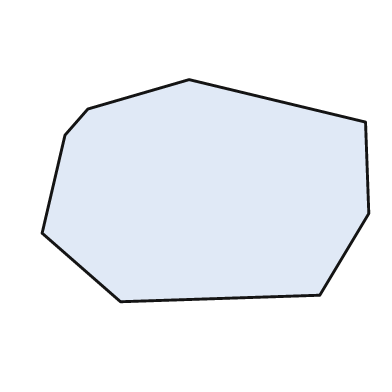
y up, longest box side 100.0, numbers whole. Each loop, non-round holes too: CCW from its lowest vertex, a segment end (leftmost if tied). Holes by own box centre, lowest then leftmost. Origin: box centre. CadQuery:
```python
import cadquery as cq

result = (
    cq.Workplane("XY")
    .moveTo(-26.0, -34.0)
    .lineTo(35.0, -32.0)
    .lineTo(50.0, -7.0)
    .lineTo(49.0, 21.0)
    .lineTo(-5.0, 34.0)
    .lineTo(-36.0, 25.0)
    .lineTo(-43.0, 17.0)
    .lineTo(-50.0, -13.0)
    .close()
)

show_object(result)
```